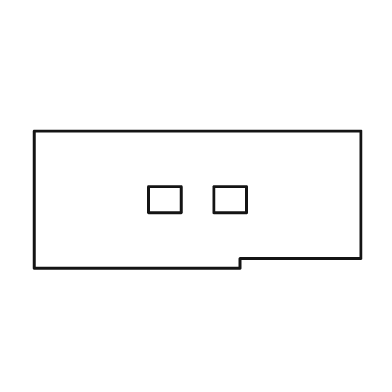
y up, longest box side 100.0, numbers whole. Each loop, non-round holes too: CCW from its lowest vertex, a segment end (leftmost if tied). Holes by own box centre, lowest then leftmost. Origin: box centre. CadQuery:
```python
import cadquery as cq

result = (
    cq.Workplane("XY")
    .moveTo(-50.0, -21.0)
    .lineTo(13.0, -21.0)
    .lineTo(13.0, -18.0)
    .lineTo(50.0, -18.0)
    .lineTo(50.0, 21.0)
    .lineTo(-50.0, 21.0)
    .close()
    .moveTo(-15.0, -4.0)
    .lineTo(-5.0, -4.0)
    .lineTo(-5.0, 4.0)
    .lineTo(-15.0, 4.0)
    .close()
    .moveTo(5.0, -4.0)
    .lineTo(15.0, -4.0)
    .lineTo(15.0, 4.0)
    .lineTo(5.0, 4.0)
    .close()
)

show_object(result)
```